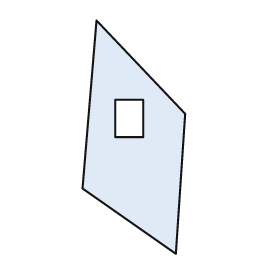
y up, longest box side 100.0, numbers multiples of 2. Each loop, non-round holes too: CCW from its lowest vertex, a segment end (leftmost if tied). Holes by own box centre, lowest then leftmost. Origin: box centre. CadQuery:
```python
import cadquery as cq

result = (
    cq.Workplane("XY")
    .moveTo(18.0, -50.0)
    .lineTo(22.0, 10.0)
    .lineTo(-16.0, 50.0)
    .lineTo(-22.0, -22.0)
    .close()
    .moveTo(-8.0, 0.0)
    .lineTo(4.0, 0.0)
    .lineTo(4.0, 16.0)
    .lineTo(-8.0, 16.0)
    .close()
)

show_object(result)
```